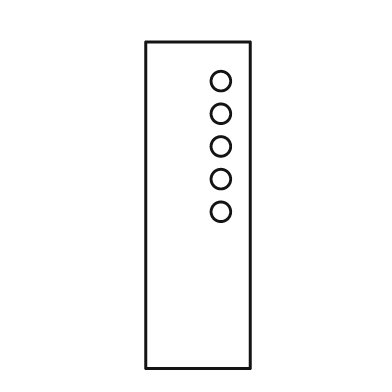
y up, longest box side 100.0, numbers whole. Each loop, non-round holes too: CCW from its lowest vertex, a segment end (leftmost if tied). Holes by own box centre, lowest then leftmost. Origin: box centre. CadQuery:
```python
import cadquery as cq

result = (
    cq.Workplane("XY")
    .moveTo(-16.0, -50.0)
    .lineTo(16.0, -50.0)
    .lineTo(16.0, 50.0)
    .lineTo(-16.0, 50.0)
    .close()
    .moveTo(7.0, -2.0)
    .circle(3.0)
    .moveTo(7.0, 8.0)
    .circle(3.0)
    .moveTo(7.0, 18.0)
    .circle(3.0)
    .moveTo(7.0, 28.0)
    .circle(3.0)
    .moveTo(7.0, 38.0)
    .circle(3.0)
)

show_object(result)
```